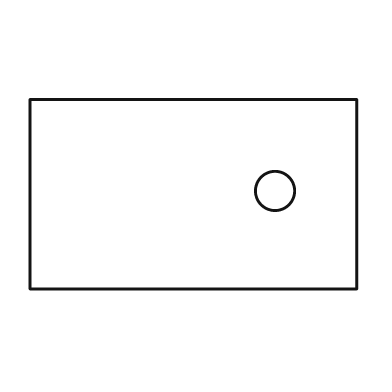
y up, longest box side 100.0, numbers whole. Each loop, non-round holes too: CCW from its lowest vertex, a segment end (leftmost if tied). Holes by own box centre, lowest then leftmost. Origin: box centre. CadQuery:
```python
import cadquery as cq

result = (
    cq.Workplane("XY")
    .moveTo(-50.0, -29.0)
    .lineTo(50.0, -29.0)
    .lineTo(50.0, 29.0)
    .lineTo(-50.0, 29.0)
    .close()
    .moveTo(25.0, 1.0)
    .circle(6.0)
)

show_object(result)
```